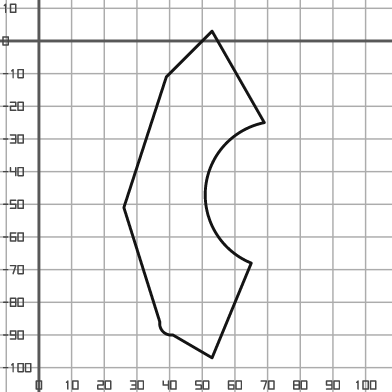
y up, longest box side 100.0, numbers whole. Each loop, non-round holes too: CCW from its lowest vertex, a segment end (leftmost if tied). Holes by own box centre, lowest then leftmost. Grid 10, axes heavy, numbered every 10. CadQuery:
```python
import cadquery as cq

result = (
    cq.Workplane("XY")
    .moveTo(53.0, -97.0)
    .lineTo(65.0, -68.0)
    .threePointArc((51.0, -45.0), (69.0, -25.0))
    .lineTo(53.0, 3.0)
    .lineTo(39.0, -11.0)
    .lineTo(26.0, -51.0)
    .lineTo(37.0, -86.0)
    .threePointArc((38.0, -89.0), (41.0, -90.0))
    .close()
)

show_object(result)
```